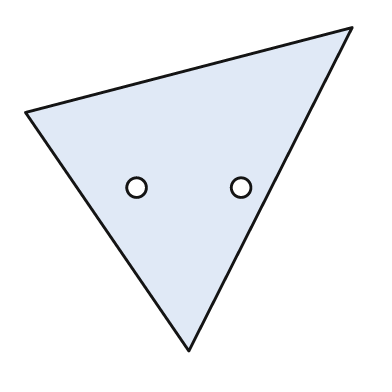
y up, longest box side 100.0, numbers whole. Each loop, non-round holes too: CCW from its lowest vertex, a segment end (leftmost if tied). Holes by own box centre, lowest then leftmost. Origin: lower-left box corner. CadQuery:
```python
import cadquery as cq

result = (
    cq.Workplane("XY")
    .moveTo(50.0, 0.0)
    .lineTo(100.0, 99.0)
    .lineTo(0.0, 73.0)
    .close()
    .moveTo(34.0, 50.0)
    .circle(3.0)
    .moveTo(66.0, 50.0)
    .circle(3.0)
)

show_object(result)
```